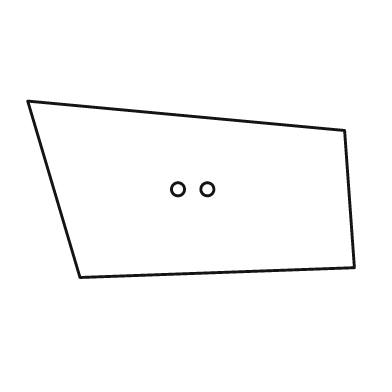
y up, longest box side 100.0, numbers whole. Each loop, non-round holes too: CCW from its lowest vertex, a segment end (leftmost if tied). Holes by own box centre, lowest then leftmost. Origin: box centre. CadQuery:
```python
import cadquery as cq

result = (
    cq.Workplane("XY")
    .moveTo(-34.0, -27.0)
    .lineTo(50.0, -24.0)
    .lineTo(47.0, 18.0)
    .lineTo(-50.0, 27.0)
    .close()
    .moveTo(-4.0, 0.0)
    .circle(2.0)
    .moveTo(5.0, 0.0)
    .circle(2.0)
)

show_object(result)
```